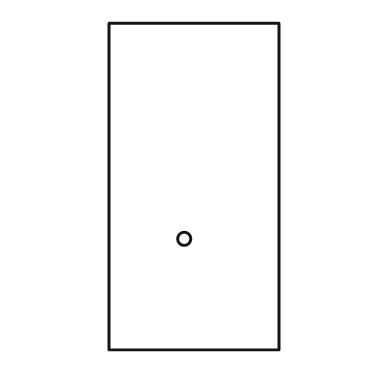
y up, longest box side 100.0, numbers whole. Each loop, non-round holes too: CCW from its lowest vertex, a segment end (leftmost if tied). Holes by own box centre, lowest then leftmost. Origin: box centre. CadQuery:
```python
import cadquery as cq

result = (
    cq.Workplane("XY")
    .moveTo(-26.0, -50.0)
    .lineTo(26.0, -50.0)
    .lineTo(26.0, 50.0)
    .lineTo(-26.0, 50.0)
    .close()
    .moveTo(-3.0, -16.0)
    .circle(2.0)
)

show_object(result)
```